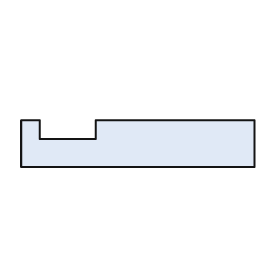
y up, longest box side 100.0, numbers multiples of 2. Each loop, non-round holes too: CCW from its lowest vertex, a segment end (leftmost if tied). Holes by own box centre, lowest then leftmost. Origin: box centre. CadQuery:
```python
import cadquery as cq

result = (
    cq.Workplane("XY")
    .moveTo(-50.0, -10.0)
    .lineTo(50.0, -10.0)
    .lineTo(50.0, 10.0)
    .lineTo(-18.0, 10.0)
    .lineTo(-18.0, 2.0)
    .lineTo(-42.0, 2.0)
    .lineTo(-42.0, 10.0)
    .lineTo(-50.0, 10.0)
    .close()
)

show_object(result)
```